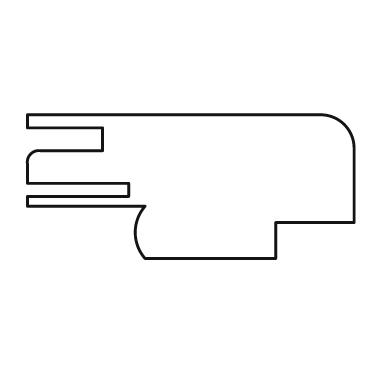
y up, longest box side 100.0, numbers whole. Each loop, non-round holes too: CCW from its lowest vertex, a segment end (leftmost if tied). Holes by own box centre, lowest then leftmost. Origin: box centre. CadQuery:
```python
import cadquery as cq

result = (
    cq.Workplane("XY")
    .moveTo(-14.0, -22.0)
    .lineTo(26.0, -22.0)
    .lineTo(26.0, -11.0)
    .lineTo(50.0, -11.0)
    .lineTo(50.0, 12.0)
    .threePointArc((47.0, 19.0), (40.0, 22.0))
    .lineTo(-50.0, 22.0)
    .lineTo(-50.0, 18.0)
    .lineTo(-27.0, 18.0)
    .lineTo(-27.0, 11.0)
    .lineTo(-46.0, 11.0)
    .threePointArc((-49.0, 10.0), (-50.0, 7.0))
    .lineTo(-50.0, 1.0)
    .lineTo(-19.0, 1.0)
    .lineTo(-19.0, -3.0)
    .lineTo(-50.0, -3.0)
    .lineTo(-50.0, -6.0)
    .lineTo(-14.0, -6.0)
    .threePointArc((-17.0, -14.0), (-14.0, -22.0))
    .close()
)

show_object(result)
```